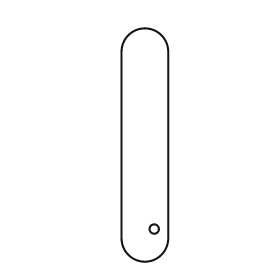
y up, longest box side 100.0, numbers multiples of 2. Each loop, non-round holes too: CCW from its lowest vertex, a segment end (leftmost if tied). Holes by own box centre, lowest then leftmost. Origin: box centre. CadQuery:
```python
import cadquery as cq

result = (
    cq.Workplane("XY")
    .moveTo(-10.0, -40.0)
    .threePointArc((0.0, -50.0), (10.0, -40.0))
    .lineTo(10.0, 40.0)
    .threePointArc((0.0, 50.0), (-10.0, 40.0))
    .close()
    .moveTo(4.0, -36.0)
    .circle(2.0)
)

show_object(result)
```